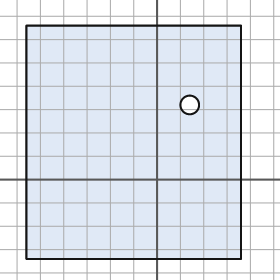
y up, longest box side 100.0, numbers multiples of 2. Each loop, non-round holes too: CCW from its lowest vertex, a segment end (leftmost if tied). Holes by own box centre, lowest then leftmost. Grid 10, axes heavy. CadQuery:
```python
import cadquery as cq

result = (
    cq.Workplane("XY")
    .moveTo(-56.0, -34.0)
    .lineTo(36.0, -34.0)
    .lineTo(36.0, 66.0)
    .lineTo(-56.0, 66.0)
    .close()
    .moveTo(14.0, 32.0)
    .circle(4.0)
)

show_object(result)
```